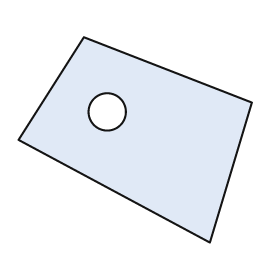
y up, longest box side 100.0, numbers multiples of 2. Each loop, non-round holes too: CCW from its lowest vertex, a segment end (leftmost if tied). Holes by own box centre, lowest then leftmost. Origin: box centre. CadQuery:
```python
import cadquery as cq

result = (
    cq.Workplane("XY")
    .moveTo(32.0, -44.0)
    .lineTo(50.0, 16.0)
    .lineTo(-22.0, 44.0)
    .lineTo(-50.0, 0.0)
    .close()
    .moveTo(-12.0, 12.0)
    .circle(8.0)
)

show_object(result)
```